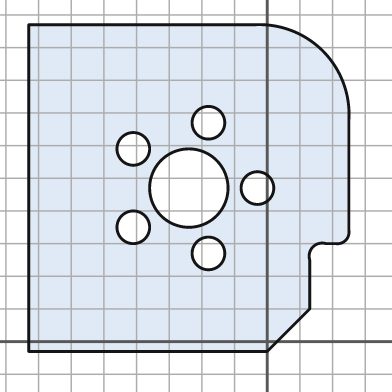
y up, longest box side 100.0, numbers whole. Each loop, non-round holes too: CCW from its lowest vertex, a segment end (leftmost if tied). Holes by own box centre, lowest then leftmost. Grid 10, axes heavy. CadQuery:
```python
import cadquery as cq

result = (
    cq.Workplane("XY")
    .moveTo(-73.0, -3.0)
    .lineTo(0.0, -3.0)
    .lineTo(13.0, 10.0)
    .lineTo(13.0, 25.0)
    .threePointArc((14.0, 29.0), (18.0, 30.0))
    .lineTo(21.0, 30.0)
    .threePointArc((24.0, 31.0), (25.0, 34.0))
    .lineTo(25.0, 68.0)
    .threePointArc((17.0, 89.0), (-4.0, 97.0))
    .lineTo(-73.0, 97.0)
    .close()
    .moveTo(-18.0, 27.0)
    .circle(5.0)
    .moveTo(-41.0, 35.0)
    .circle(5.0)
    .moveTo(-24.0, 47.0)
    .circle(12.0)
    .moveTo(-3.0, 47.0)
    .circle(5.0)
    .moveTo(-41.0, 59.0)
    .circle(5.0)
    .moveTo(-18.0, 67.0)
    .circle(5.0)
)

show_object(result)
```